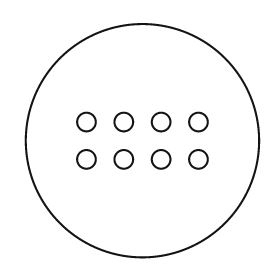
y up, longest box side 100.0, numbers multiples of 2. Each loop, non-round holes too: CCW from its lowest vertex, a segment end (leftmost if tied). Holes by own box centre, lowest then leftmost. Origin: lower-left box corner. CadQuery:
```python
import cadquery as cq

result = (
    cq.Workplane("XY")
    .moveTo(50.0, 50.0)
    .circle(50.0)
    .moveTo(26.0, 42.0)
    .circle(4.0)
    .moveTo(42.0, 42.0)
    .circle(4.0)
    .moveTo(58.0, 42.0)
    .circle(4.0)
    .moveTo(74.0, 42.0)
    .circle(4.0)
    .moveTo(26.0, 58.0)
    .circle(4.0)
    .moveTo(42.0, 58.0)
    .circle(4.0)
    .moveTo(58.0, 58.0)
    .circle(4.0)
    .moveTo(74.0, 58.0)
    .circle(4.0)
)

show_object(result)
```